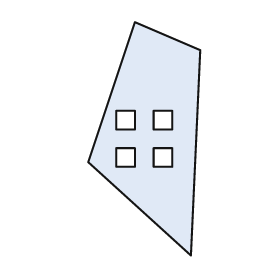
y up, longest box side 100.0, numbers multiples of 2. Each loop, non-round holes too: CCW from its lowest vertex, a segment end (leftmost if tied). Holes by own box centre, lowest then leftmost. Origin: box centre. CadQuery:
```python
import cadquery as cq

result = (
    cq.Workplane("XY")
    .moveTo(20.0, -50.0)
    .lineTo(24.0, 38.0)
    .lineTo(-4.0, 50.0)
    .lineTo(-24.0, -10.0)
    .close()
    .moveTo(-12.0, -12.0)
    .lineTo(-4.0, -12.0)
    .lineTo(-4.0, -4.0)
    .lineTo(-12.0, -4.0)
    .close()
    .moveTo(4.0, -12.0)
    .lineTo(12.0, -12.0)
    .lineTo(12.0, -4.0)
    .lineTo(4.0, -4.0)
    .close()
    .moveTo(-12.0, 4.0)
    .lineTo(-4.0, 4.0)
    .lineTo(-4.0, 12.0)
    .lineTo(-12.0, 12.0)
    .close()
    .moveTo(4.0, 4.0)
    .lineTo(12.0, 4.0)
    .lineTo(12.0, 12.0)
    .lineTo(4.0, 12.0)
    .close()
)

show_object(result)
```